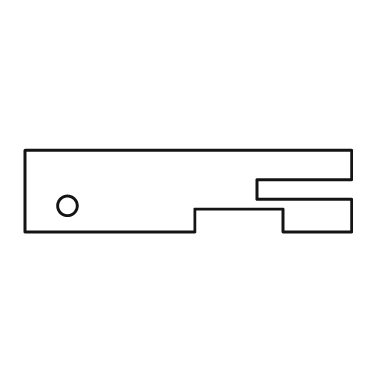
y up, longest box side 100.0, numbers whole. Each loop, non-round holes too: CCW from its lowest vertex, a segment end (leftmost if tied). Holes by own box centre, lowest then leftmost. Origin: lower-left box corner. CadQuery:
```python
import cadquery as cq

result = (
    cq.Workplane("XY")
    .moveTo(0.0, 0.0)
    .lineTo(52.0, 0.0)
    .lineTo(52.0, 7.0)
    .lineTo(79.0, 7.0)
    .lineTo(79.0, 0.0)
    .lineTo(100.0, 0.0)
    .lineTo(100.0, 10.0)
    .lineTo(71.0, 10.0)
    .lineTo(71.0, 16.0)
    .lineTo(100.0, 16.0)
    .lineTo(100.0, 25.0)
    .lineTo(0.0, 25.0)
    .close()
    .moveTo(13.0, 8.0)
    .circle(3.0)
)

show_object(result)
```